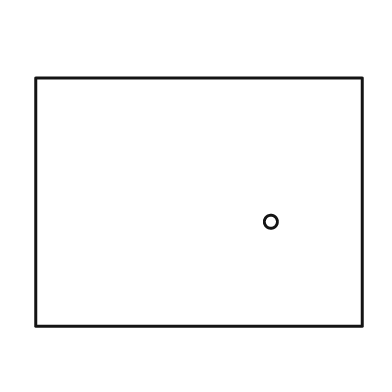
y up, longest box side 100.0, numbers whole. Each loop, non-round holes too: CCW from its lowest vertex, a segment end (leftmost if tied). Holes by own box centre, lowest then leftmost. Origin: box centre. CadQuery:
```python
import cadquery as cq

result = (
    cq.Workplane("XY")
    .moveTo(-50.0, -38.0)
    .lineTo(50.0, -38.0)
    .lineTo(50.0, 38.0)
    .lineTo(-50.0, 38.0)
    .close()
    .moveTo(22.0, -6.0)
    .circle(2.0)
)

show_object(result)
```